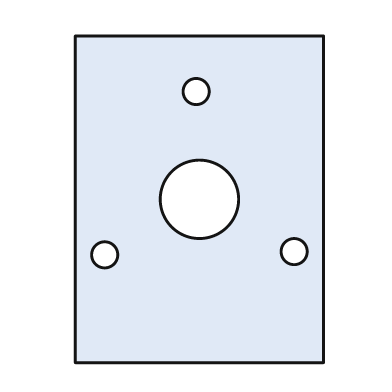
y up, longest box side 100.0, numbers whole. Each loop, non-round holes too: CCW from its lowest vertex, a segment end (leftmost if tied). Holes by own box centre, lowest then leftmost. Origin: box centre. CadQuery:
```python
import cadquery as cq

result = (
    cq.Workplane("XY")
    .moveTo(-38.0, -50.0)
    .lineTo(38.0, -50.0)
    .lineTo(38.0, 50.0)
    .lineTo(-38.0, 50.0)
    .close()
    .moveTo(-29.0, -17.0)
    .circle(4.0)
    .moveTo(29.0, -16.0)
    .circle(4.0)
    .moveTo(0.0, 0.0)
    .circle(12.0)
    .moveTo(-1.0, 33.0)
    .circle(4.0)
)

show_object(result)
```